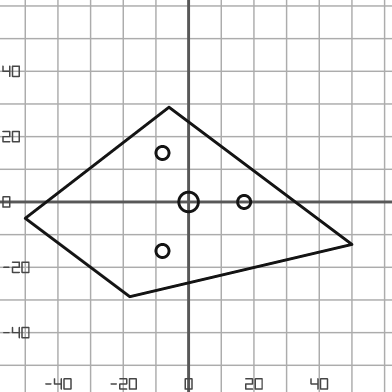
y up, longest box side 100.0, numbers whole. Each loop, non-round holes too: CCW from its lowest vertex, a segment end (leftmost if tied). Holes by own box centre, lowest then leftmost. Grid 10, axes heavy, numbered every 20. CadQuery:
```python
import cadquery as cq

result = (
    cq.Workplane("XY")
    .moveTo(-18.0, -29.0)
    .lineTo(50.0, -13.0)
    .lineTo(-6.0, 29.0)
    .lineTo(-50.0, -5.0)
    .close()
    .moveTo(-8.0, -15.0)
    .circle(2.0)
    .moveTo(0.0, 0.0)
    .circle(3.0)
    .moveTo(17.0, 0.0)
    .circle(2.0)
    .moveTo(-8.0, 15.0)
    .circle(2.0)
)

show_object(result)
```